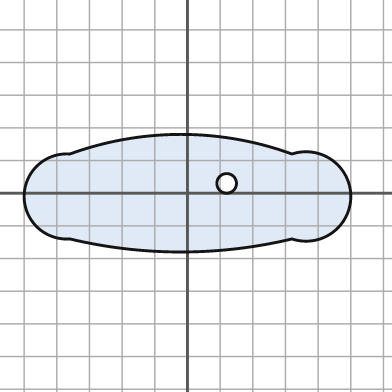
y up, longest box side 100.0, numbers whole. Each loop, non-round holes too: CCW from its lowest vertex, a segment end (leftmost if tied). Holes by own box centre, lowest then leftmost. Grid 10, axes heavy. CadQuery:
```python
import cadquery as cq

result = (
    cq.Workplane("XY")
    .moveTo(-36.0, -14.0)
    .threePointArc((-2.0, -18.0), (32.0, -14.0))
    .threePointArc((50.0, -1.0), (32.0, 12.0))
    .threePointArc((-2.0, 18.0), (-36.0, 12.0))
    .threePointArc((-50.0, -1.0), (-36.0, -14.0))
    .close()
    .moveTo(12.0, 3.0)
    .circle(3.0)
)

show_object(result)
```